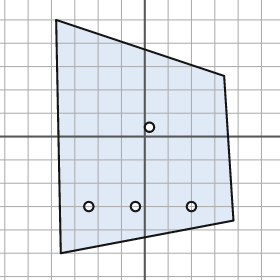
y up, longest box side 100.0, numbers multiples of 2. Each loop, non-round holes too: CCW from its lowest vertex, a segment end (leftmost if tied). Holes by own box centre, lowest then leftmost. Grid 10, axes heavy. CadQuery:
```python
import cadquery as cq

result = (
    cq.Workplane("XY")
    .moveTo(-36.0, -50.0)
    .lineTo(38.0, -36.0)
    .lineTo(34.0, 26.0)
    .lineTo(-38.0, 50.0)
    .close()
    .moveTo(-24.0, -30.0)
    .circle(2.0)
    .moveTo(-4.0, -30.0)
    .circle(2.0)
    .moveTo(20.0, -30.0)
    .circle(2.0)
    .moveTo(2.0, 4.0)
    .circle(2.0)
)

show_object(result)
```